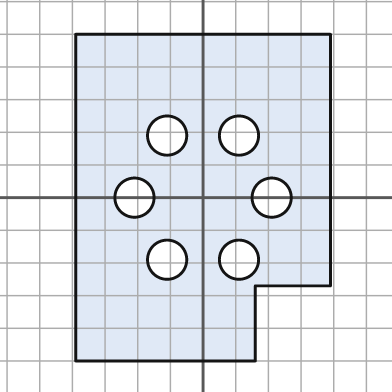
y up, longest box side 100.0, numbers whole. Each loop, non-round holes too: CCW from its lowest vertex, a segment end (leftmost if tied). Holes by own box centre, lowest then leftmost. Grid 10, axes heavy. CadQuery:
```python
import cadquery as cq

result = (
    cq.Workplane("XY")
    .moveTo(-39.0, -50.0)
    .lineTo(16.0, -50.0)
    .lineTo(16.0, -27.0)
    .lineTo(39.0, -27.0)
    .lineTo(39.0, 50.0)
    .lineTo(-39.0, 50.0)
    .close()
    .moveTo(-11.0, -19.0)
    .circle(6.0)
    .moveTo(11.0, -19.0)
    .circle(6.0)
    .moveTo(-21.0, 0.0)
    .circle(6.0)
    .moveTo(21.0, 0.0)
    .circle(6.0)
    .moveTo(-11.0, 19.0)
    .circle(6.0)
    .moveTo(11.0, 19.0)
    .circle(6.0)
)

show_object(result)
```